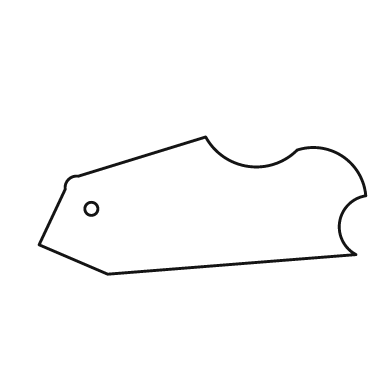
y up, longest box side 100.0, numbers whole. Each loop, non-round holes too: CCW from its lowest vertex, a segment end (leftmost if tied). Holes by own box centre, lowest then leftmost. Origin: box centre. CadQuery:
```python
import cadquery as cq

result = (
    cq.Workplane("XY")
    .moveTo(-29.0, -21.0)
    .lineTo(47.0, -15.0)
    .threePointArc((42.0, -5.0), (50.0, 3.0))
    .threePointArc((43.0, 15.0), (29.0, 17.0))
    .threePointArc((14.0, 12.0), (1.0, 21.0))
    .lineTo(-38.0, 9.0)
    .threePointArc((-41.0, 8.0), (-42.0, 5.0))
    .lineTo(-50.0, -12.0)
    .close()
    .moveTo(-34.0, -1.0)
    .circle(2.0)
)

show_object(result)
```